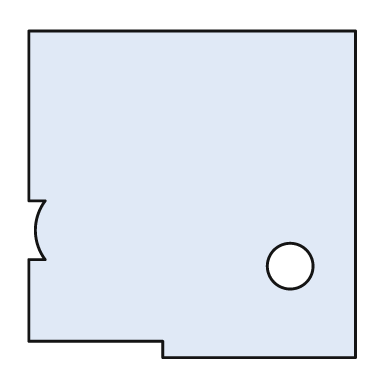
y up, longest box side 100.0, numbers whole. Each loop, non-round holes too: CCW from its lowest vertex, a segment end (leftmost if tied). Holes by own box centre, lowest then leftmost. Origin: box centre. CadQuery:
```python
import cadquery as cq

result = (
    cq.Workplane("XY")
    .moveTo(-9.0, -50.0)
    .lineTo(50.0, -50.0)
    .lineTo(50.0, 50.0)
    .lineTo(-50.0, 50.0)
    .lineTo(-50.0, -2.0)
    .lineTo(-45.0, -2.0)
    .threePointArc((-48.0, -11.0), (-45.0, -20.0))
    .lineTo(-50.0, -20.0)
    .lineTo(-50.0, -45.0)
    .lineTo(-9.0, -45.0)
    .close()
    .moveTo(30.0, -22.0)
    .circle(7.0)
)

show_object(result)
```